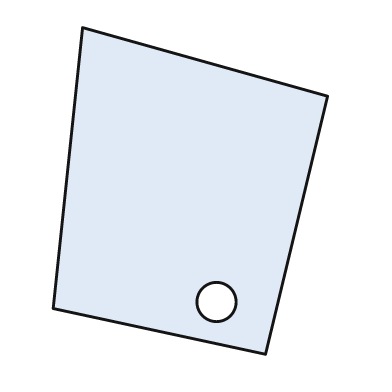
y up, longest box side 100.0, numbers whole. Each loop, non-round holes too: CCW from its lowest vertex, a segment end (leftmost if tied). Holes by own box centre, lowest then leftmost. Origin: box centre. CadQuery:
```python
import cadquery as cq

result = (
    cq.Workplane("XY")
    .moveTo(23.0, -50.0)
    .lineTo(42.0, 29.0)
    .lineTo(-33.0, 50.0)
    .lineTo(-42.0, -36.0)
    .close()
    .moveTo(8.0, -34.0)
    .circle(6.0)
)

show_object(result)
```